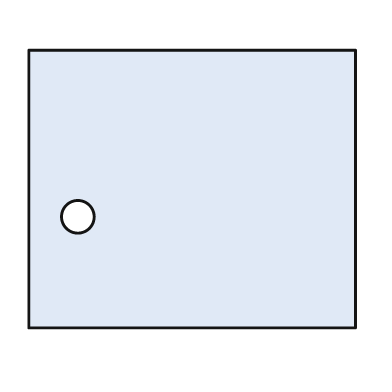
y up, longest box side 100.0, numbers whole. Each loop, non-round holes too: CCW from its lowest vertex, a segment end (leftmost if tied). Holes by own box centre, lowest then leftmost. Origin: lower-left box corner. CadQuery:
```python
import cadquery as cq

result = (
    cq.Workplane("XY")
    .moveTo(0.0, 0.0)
    .lineTo(100.0, 0.0)
    .lineTo(100.0, 85.0)
    .lineTo(0.0, 85.0)
    .close()
    .moveTo(15.0, 34.0)
    .circle(5.0)
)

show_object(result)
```